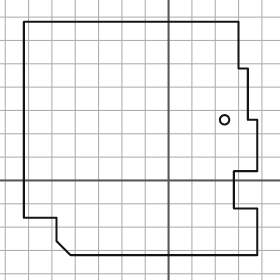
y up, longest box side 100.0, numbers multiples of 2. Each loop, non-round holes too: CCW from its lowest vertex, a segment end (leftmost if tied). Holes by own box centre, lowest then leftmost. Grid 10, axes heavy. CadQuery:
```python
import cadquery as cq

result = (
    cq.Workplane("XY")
    .moveTo(-42.0, -32.0)
    .lineTo(38.0, -32.0)
    .lineTo(38.0, -12.0)
    .lineTo(28.0, -12.0)
    .lineTo(28.0, 4.0)
    .lineTo(38.0, 4.0)
    .lineTo(38.0, 26.0)
    .lineTo(34.0, 26.0)
    .lineTo(34.0, 48.0)
    .lineTo(30.0, 48.0)
    .lineTo(30.0, 68.0)
    .lineTo(-62.0, 68.0)
    .lineTo(-62.0, -16.0)
    .lineTo(-48.0, -16.0)
    .lineTo(-48.0, -26.0)
    .close()
    .moveTo(24.0, 26.0)
    .circle(2.0)
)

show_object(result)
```